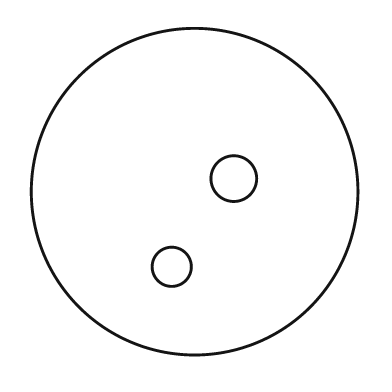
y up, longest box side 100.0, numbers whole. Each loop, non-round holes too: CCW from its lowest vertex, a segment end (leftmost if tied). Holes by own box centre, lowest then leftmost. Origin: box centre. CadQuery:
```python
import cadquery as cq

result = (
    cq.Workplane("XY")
    .moveTo(0.0, 0.0)
    .circle(50.0)
    .moveTo(-7.0, -23.0)
    .circle(6.0)
    .moveTo(12.0, 4.0)
    .circle(7.0)
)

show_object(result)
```